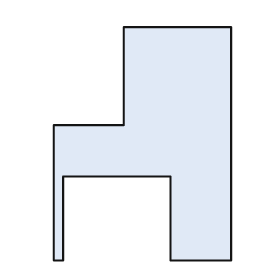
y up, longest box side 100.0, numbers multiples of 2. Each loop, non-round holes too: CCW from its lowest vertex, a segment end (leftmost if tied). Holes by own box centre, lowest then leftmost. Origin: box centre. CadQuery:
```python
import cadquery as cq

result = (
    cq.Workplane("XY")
    .moveTo(-38.0, -50.0)
    .lineTo(-34.0, -50.0)
    .lineTo(-34.0, -14.0)
    .lineTo(12.0, -14.0)
    .lineTo(12.0, -50.0)
    .lineTo(38.0, -50.0)
    .lineTo(38.0, 50.0)
    .lineTo(-8.0, 50.0)
    .lineTo(-8.0, 8.0)
    .lineTo(-38.0, 8.0)
    .close()
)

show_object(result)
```